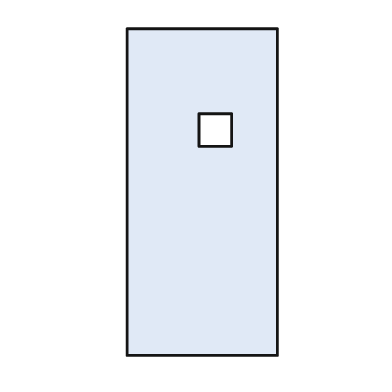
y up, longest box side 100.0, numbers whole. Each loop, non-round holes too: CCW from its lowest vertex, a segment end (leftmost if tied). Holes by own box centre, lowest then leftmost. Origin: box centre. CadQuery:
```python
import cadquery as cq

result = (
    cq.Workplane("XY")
    .moveTo(-23.0, -50.0)
    .lineTo(23.0, -50.0)
    .lineTo(23.0, 50.0)
    .lineTo(-23.0, 50.0)
    .close()
    .moveTo(-1.0, 14.0)
    .lineTo(9.0, 14.0)
    .lineTo(9.0, 24.0)
    .lineTo(-1.0, 24.0)
    .close()
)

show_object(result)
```